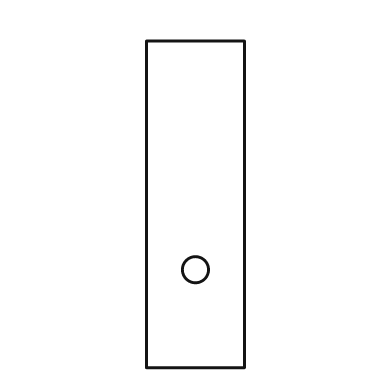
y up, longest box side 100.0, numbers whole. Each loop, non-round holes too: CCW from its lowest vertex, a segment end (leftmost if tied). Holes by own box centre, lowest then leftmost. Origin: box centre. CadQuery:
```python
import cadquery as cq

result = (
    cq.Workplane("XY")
    .moveTo(-15.0, -50.0)
    .lineTo(15.0, -50.0)
    .lineTo(15.0, 50.0)
    .lineTo(-15.0, 50.0)
    .close()
    .moveTo(0.0, -20.0)
    .circle(4.0)
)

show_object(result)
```